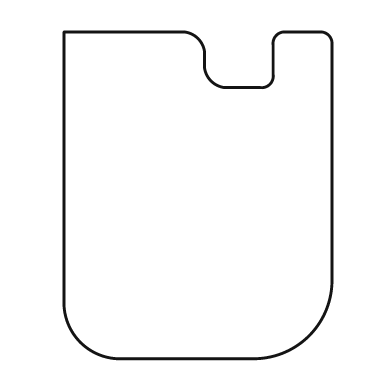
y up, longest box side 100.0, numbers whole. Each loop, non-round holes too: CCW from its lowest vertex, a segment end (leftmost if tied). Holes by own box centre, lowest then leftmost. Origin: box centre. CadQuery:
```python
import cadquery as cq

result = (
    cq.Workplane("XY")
    .moveTo(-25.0, -50.0)
    .lineTo(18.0, -50.0)
    .threePointArc((34.0, -43.0), (41.0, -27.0))
    .lineTo(41.0, 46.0)
    .threePointArc((40.0, 49.0), (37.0, 50.0))
    .lineTo(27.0, 50.0)
    .threePointArc((24.0, 49.0), (23.0, 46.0))
    .lineTo(23.0, 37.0)
    .threePointArc((22.0, 34.0), (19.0, 33.0))
    .lineTo(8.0, 33.0)
    .threePointArc((4.0, 35.0), (2.0, 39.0))
    .lineTo(2.0, 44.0)
    .threePointArc((0.0, 48.0), (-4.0, 50.0))
    .lineTo(-41.0, 50.0)
    .lineTo(-41.0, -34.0)
    .threePointArc((-36.0, -45.0), (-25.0, -50.0))
    .close()
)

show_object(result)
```